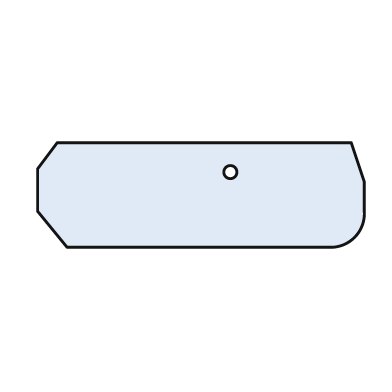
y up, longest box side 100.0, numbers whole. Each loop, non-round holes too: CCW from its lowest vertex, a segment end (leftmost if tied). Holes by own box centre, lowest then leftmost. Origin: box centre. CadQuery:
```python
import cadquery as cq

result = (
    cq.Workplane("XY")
    .moveTo(-41.0, -16.0)
    .lineTo(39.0, -16.0)
    .threePointArc((47.0, -13.0), (50.0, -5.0))
    .lineTo(50.0, 4.0)
    .lineTo(46.0, 16.0)
    .lineTo(-44.0, 16.0)
    .lineTo(-50.0, 8.0)
    .lineTo(-50.0, -5.0)
    .close()
    .moveTo(9.0, 7.0)
    .circle(2.0)
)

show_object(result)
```